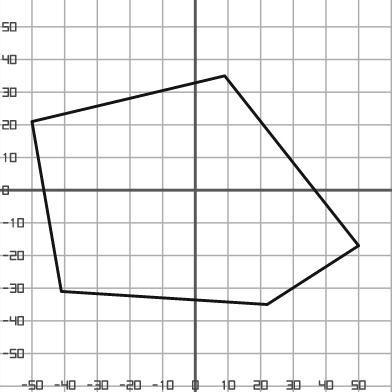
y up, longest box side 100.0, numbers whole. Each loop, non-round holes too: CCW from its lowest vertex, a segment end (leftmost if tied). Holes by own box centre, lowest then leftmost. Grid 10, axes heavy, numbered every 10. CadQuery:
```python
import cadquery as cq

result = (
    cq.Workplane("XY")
    .moveTo(22.0, -35.0)
    .lineTo(50.0, -17.0)
    .lineTo(9.0, 35.0)
    .lineTo(-50.0, 21.0)
    .lineTo(-41.0, -31.0)
    .close()
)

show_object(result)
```